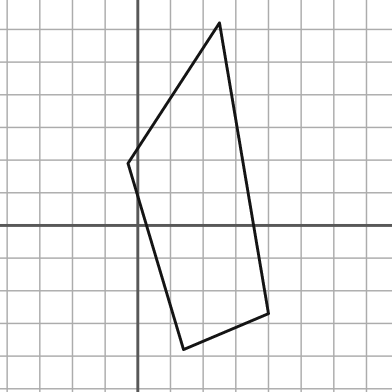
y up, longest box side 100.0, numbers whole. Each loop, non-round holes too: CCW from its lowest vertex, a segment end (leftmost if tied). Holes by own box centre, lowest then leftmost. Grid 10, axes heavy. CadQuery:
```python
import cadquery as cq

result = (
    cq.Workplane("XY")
    .moveTo(14.0, -38.0)
    .lineTo(40.0, -27.0)
    .lineTo(25.0, 62.0)
    .lineTo(-3.0, 19.0)
    .close()
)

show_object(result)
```